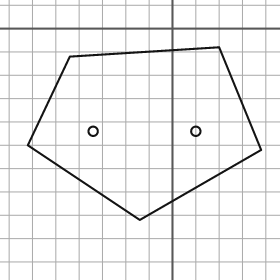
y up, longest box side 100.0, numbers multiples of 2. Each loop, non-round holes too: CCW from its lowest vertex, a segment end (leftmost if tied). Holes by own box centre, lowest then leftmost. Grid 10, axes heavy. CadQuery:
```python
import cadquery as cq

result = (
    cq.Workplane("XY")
    .moveTo(-14.0, -82.0)
    .lineTo(38.0, -52.0)
    .lineTo(20.0, -8.0)
    .lineTo(-44.0, -12.0)
    .lineTo(-62.0, -50.0)
    .close()
    .moveTo(-34.0, -44.0)
    .circle(2.0)
    .moveTo(10.0, -44.0)
    .circle(2.0)
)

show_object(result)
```